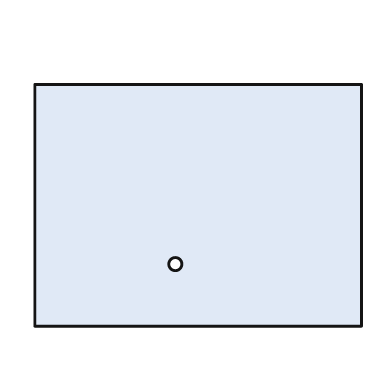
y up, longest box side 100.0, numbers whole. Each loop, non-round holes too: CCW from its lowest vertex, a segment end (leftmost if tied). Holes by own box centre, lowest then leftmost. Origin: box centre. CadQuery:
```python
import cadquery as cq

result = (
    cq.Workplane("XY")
    .moveTo(-50.0, -37.0)
    .lineTo(50.0, -37.0)
    .lineTo(50.0, 37.0)
    .lineTo(-50.0, 37.0)
    .close()
    .moveTo(-7.0, -18.0)
    .circle(2.0)
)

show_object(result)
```